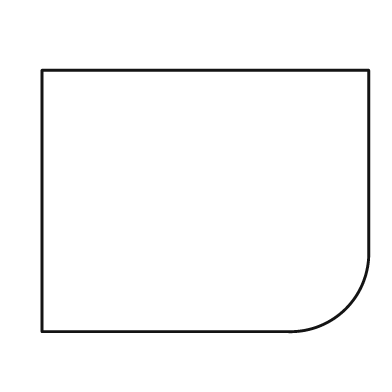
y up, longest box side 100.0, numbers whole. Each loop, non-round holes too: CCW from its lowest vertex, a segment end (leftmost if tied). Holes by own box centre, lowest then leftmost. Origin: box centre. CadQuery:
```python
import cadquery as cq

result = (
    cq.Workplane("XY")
    .moveTo(-50.0, -40.0)
    .lineTo(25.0, -40.0)
    .threePointArc((43.0, -33.0), (50.0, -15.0))
    .lineTo(50.0, 40.0)
    .lineTo(-50.0, 40.0)
    .close()
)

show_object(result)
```